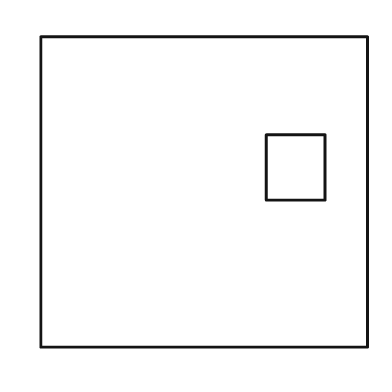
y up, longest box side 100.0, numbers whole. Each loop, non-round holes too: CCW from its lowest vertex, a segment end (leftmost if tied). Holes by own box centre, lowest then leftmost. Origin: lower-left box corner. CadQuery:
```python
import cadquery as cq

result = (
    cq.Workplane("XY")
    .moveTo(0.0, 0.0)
    .lineTo(100.0, 0.0)
    .lineTo(100.0, 95.0)
    .lineTo(0.0, 95.0)
    .close()
    .moveTo(69.0, 45.0)
    .lineTo(87.0, 45.0)
    .lineTo(87.0, 65.0)
    .lineTo(69.0, 65.0)
    .close()
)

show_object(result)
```